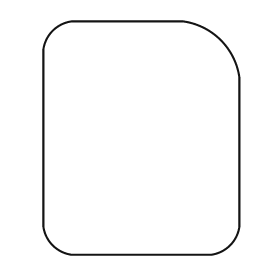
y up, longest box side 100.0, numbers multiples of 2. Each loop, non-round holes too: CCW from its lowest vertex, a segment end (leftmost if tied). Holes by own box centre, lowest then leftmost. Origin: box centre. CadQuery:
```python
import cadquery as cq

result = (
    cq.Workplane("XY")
    .moveTo(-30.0, -50.0)
    .lineTo(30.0, -50.0)
    .threePointArc((38.0, -46.0), (42.0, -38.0))
    .lineTo(42.0, 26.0)
    .threePointArc((34.0, 42.0), (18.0, 50.0))
    .lineTo(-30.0, 50.0)
    .threePointArc((-38.0, 46.0), (-42.0, 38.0))
    .lineTo(-42.0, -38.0)
    .threePointArc((-38.0, -46.0), (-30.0, -50.0))
    .close()
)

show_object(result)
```